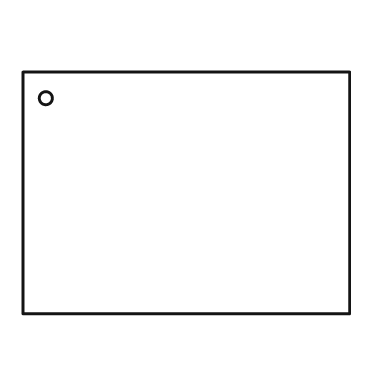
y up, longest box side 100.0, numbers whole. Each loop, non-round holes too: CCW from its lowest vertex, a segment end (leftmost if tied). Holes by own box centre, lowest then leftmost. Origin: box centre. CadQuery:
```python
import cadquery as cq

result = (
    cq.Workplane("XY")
    .moveTo(-50.0, -37.0)
    .lineTo(50.0, -37.0)
    .lineTo(50.0, 37.0)
    .lineTo(-50.0, 37.0)
    .close()
    .moveTo(-43.0, 29.0)
    .circle(2.0)
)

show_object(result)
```